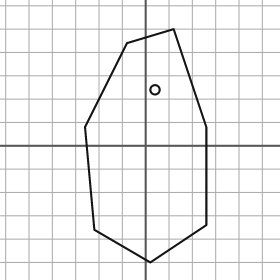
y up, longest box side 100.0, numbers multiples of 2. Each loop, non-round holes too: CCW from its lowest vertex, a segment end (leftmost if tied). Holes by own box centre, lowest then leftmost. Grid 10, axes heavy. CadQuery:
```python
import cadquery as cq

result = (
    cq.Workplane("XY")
    .moveTo(2.0, -50.0)
    .lineTo(26.0, -34.0)
    .lineTo(26.0, 8.0)
    .lineTo(12.0, 50.0)
    .lineTo(-8.0, 44.0)
    .lineTo(-26.0, 8.0)
    .lineTo(-22.0, -36.0)
    .close()
    .moveTo(4.0, 24.0)
    .circle(2.0)
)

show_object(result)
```